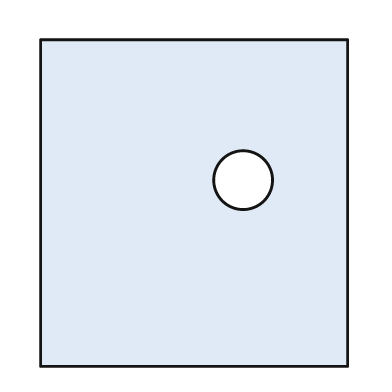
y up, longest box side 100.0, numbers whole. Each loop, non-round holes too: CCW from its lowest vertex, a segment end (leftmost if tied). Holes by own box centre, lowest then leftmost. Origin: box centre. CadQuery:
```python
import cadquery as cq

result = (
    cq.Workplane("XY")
    .moveTo(-47.0, -50.0)
    .lineTo(47.0, -50.0)
    .lineTo(47.0, 50.0)
    .lineTo(-47.0, 50.0)
    .close()
    .moveTo(15.0, 7.0)
    .circle(9.0)
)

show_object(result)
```